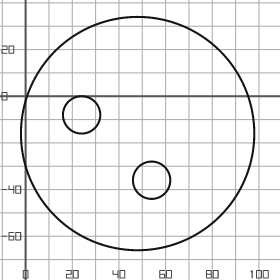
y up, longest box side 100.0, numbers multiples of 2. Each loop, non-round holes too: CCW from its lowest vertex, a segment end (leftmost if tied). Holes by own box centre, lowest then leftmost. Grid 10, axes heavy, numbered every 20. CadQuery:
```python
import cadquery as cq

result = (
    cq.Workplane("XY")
    .moveTo(48.0, -16.0)
    .circle(50.0)
    .moveTo(54.0, -36.0)
    .circle(8.0)
    .moveTo(24.0, -8.0)
    .circle(8.0)
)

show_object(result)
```